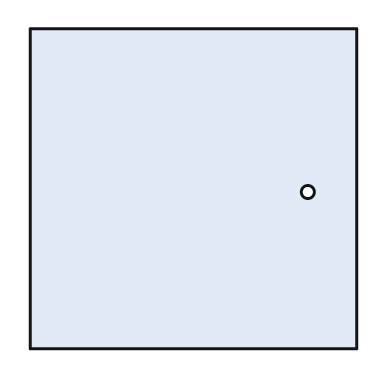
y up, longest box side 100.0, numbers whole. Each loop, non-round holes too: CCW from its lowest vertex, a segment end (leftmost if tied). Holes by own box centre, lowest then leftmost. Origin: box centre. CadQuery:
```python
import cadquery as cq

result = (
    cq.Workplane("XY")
    .moveTo(-50.0, -49.0)
    .lineTo(50.0, -49.0)
    .lineTo(50.0, 49.0)
    .lineTo(-50.0, 49.0)
    .close()
    .moveTo(35.0, -1.0)
    .circle(2.0)
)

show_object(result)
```